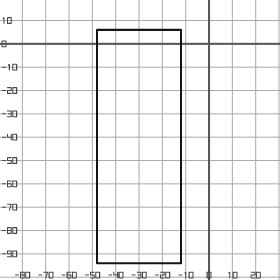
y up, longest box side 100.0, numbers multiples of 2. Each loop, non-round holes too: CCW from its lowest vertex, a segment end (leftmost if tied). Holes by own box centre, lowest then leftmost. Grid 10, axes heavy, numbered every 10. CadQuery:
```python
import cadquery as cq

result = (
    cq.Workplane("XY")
    .moveTo(-48.0, -94.0)
    .lineTo(-12.0, -94.0)
    .lineTo(-12.0, 6.0)
    .lineTo(-48.0, 6.0)
    .close()
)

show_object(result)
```